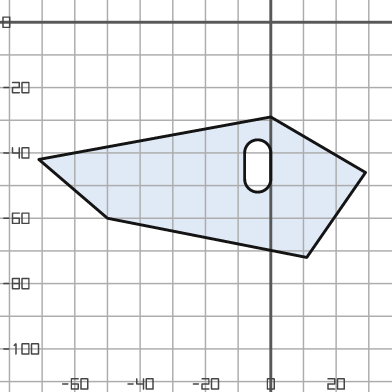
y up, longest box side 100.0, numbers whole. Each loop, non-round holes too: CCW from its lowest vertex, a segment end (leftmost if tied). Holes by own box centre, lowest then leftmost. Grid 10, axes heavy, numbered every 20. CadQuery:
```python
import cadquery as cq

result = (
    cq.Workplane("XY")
    .moveTo(11.0, -72.0)
    .lineTo(29.0, -46.0)
    .lineTo(0.0, -29.0)
    .lineTo(-71.0, -42.0)
    .lineTo(-50.0, -60.0)
    .close()
    .moveTo(-8.0, -48.0)
    .threePointArc((-4.0, -52.0), (0.0, -48.0))
    .lineTo(0.0, -40.0)
    .threePointArc((-4.0, -36.0), (-8.0, -40.0))
    .close()
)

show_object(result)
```